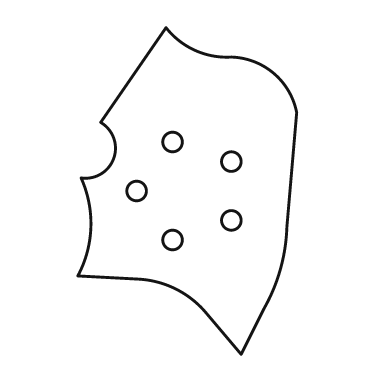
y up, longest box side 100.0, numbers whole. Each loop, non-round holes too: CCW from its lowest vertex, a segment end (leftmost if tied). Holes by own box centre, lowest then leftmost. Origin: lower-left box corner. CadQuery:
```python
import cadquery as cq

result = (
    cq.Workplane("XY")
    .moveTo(50.0, 0.0)
    .lineTo(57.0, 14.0)
    .threePointArc((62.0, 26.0), (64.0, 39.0))
    .lineTo(67.0, 74.0)
    .threePointArc((60.0, 86.0), (47.0, 91.0))
    .threePointArc((36.0, 93.0), (27.0, 100.0))
    .lineTo(7.0, 71.0)
    .threePointArc((11.0, 60.0), (1.0, 54.0))
    .threePointArc((4.0, 39.0), (0.0, 24.0))
    .lineTo(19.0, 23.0)
    .threePointArc((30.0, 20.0), (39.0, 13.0))
    .close()
    .moveTo(29.0, 35.0)
    .circle(3.0)
    .moveTo(47.0, 41.0)
    .circle(3.0)
    .moveTo(18.0, 50.0)
    .circle(3.0)
    .moveTo(47.0, 59.0)
    .circle(3.0)
    .moveTo(29.0, 65.0)
    .circle(3.0)
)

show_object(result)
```